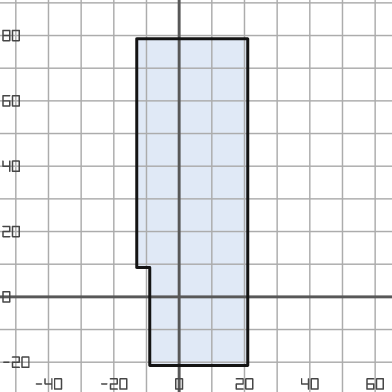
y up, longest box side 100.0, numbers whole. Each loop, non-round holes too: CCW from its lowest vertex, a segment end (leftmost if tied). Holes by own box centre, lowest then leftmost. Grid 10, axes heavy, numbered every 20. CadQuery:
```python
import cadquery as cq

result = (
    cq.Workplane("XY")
    .moveTo(-9.0, -21.0)
    .lineTo(21.0, -21.0)
    .lineTo(21.0, 79.0)
    .lineTo(-13.0, 79.0)
    .lineTo(-13.0, 9.0)
    .lineTo(-9.0, 9.0)
    .close()
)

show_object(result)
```